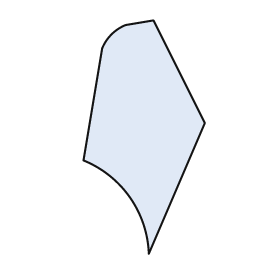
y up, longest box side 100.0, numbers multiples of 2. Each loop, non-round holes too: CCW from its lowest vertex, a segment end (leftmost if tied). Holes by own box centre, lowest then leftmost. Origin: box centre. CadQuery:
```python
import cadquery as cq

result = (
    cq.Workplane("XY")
    .moveTo(2.0, -50.0)
    .lineTo(26.0, 6.0)
    .lineTo(4.0, 50.0)
    .lineTo(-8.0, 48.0)
    .threePointArc((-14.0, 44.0), (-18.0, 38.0))
    .lineTo(-26.0, -10.0)
    .threePointArc((-6.0, -26.0), (2.0, -50.0))
    .close()
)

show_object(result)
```